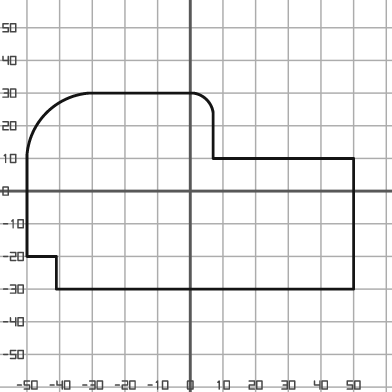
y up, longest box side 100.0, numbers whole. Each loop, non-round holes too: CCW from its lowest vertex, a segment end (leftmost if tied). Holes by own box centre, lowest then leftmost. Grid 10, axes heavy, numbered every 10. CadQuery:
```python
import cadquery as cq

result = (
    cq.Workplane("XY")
    .moveTo(-41.0, -30.0)
    .lineTo(50.0, -30.0)
    .lineTo(50.0, 10.0)
    .lineTo(7.0, 10.0)
    .lineTo(7.0, 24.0)
    .threePointArc((5.0, 28.0), (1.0, 30.0))
    .lineTo(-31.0, 30.0)
    .threePointArc((-44.0, 24.0), (-50.0, 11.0))
    .lineTo(-50.0, -20.0)
    .lineTo(-41.0, -20.0)
    .close()
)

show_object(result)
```